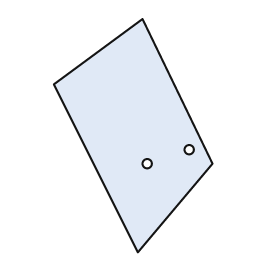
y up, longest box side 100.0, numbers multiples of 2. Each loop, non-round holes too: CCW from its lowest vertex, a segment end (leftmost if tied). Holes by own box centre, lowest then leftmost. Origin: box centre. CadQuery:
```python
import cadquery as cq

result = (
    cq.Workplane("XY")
    .moveTo(2.0, -50.0)
    .lineTo(34.0, -12.0)
    .lineTo(4.0, 50.0)
    .lineTo(-34.0, 22.0)
    .close()
    .moveTo(6.0, -12.0)
    .circle(2.0)
    .moveTo(24.0, -6.0)
    .circle(2.0)
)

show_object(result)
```